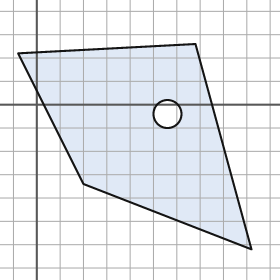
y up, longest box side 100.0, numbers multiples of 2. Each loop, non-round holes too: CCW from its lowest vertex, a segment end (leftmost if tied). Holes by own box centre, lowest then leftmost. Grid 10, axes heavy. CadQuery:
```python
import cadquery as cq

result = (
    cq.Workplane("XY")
    .moveTo(92.0, -62.0)
    .lineTo(68.0, 26.0)
    .lineTo(-8.0, 22.0)
    .lineTo(20.0, -34.0)
    .close()
    .moveTo(56.0, -4.0)
    .circle(6.0)
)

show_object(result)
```